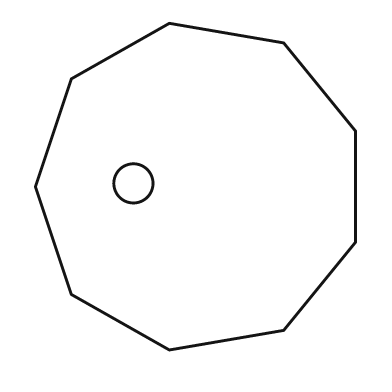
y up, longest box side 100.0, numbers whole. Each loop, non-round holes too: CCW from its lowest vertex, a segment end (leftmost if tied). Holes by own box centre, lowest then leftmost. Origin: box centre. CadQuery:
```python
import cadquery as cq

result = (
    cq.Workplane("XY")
    .moveTo(-8.0, -50.0)
    .lineTo(27.0, -44.0)
    .lineTo(49.0, -17.0)
    .lineTo(49.0, 17.0)
    .lineTo(27.0, 44.0)
    .lineTo(-8.0, 50.0)
    .lineTo(-38.0, 33.0)
    .lineTo(-49.0, 0.0)
    .lineTo(-38.0, -33.0)
    .close()
    .moveTo(-19.0, 1.0)
    .circle(6.0)
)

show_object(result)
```